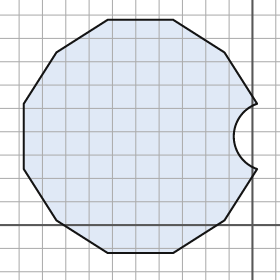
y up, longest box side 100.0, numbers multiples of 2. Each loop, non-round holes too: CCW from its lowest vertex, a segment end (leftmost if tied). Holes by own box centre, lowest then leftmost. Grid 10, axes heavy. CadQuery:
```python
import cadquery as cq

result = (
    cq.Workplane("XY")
    .moveTo(-62.0, -12.0)
    .lineTo(-34.0, -12.0)
    .lineTo(-12.0, 2.0)
    .lineTo(2.0, 24.0)
    .threePointArc((-8.0, 38.0), (2.0, 52.0))
    .lineTo(-12.0, 74.0)
    .lineTo(-34.0, 88.0)
    .lineTo(-62.0, 88.0)
    .lineTo(-84.0, 74.0)
    .lineTo(-98.0, 52.0)
    .lineTo(-98.0, 24.0)
    .lineTo(-84.0, 2.0)
    .close()
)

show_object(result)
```